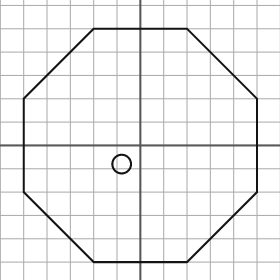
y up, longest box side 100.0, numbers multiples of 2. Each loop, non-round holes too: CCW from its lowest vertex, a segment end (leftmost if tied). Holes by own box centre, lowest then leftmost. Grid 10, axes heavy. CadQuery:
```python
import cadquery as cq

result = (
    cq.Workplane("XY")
    .moveTo(-20.0, -50.0)
    .lineTo(20.0, -50.0)
    .lineTo(50.0, -20.0)
    .lineTo(50.0, 20.0)
    .lineTo(20.0, 50.0)
    .lineTo(-20.0, 50.0)
    .lineTo(-50.0, 20.0)
    .lineTo(-50.0, -20.0)
    .close()
    .moveTo(-8.0, -8.0)
    .circle(4.0)
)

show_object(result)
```